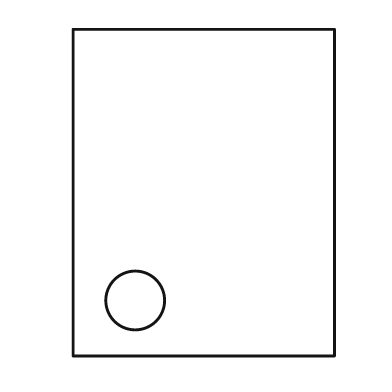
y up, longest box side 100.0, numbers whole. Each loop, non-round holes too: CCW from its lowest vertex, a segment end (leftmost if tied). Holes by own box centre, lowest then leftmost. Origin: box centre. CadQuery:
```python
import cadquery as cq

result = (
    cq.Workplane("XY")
    .moveTo(-40.0, -50.0)
    .lineTo(40.0, -50.0)
    .lineTo(40.0, 50.0)
    .lineTo(-40.0, 50.0)
    .close()
    .moveTo(-21.0, -33.0)
    .circle(9.0)
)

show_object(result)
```